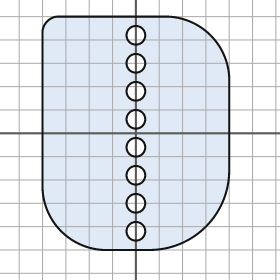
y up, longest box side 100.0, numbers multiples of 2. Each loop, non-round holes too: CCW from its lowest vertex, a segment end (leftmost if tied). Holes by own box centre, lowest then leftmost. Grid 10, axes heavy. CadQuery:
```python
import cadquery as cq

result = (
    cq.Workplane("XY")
    .moveTo(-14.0, -50.0)
    .lineTo(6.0, -50.0)
    .threePointArc((30.0, -40.0), (40.0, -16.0))
    .lineTo(40.0, 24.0)
    .threePointArc((32.0, 42.0), (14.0, 50.0))
    .lineTo(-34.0, 50.0)
    .threePointArc((-38.0, 48.0), (-40.0, 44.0))
    .lineTo(-40.0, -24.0)
    .threePointArc((-32.0, -42.0), (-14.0, -50.0))
    .close()
    .moveTo(0.0, -42.0)
    .circle(4.0)
    .moveTo(0.0, -30.0)
    .circle(4.0)
    .moveTo(0.0, -18.0)
    .circle(4.0)
    .moveTo(0.0, -6.0)
    .circle(4.0)
    .moveTo(0.0, 6.0)
    .circle(4.0)
    .moveTo(0.0, 18.0)
    .circle(4.0)
    .moveTo(0.0, 30.0)
    .circle(4.0)
    .moveTo(0.0, 42.0)
    .circle(4.0)
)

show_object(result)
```